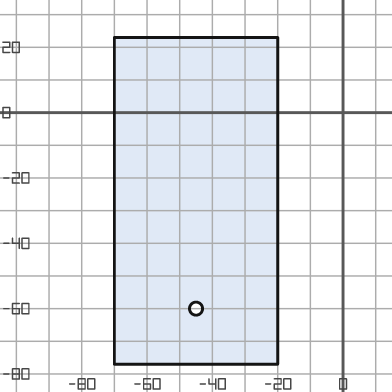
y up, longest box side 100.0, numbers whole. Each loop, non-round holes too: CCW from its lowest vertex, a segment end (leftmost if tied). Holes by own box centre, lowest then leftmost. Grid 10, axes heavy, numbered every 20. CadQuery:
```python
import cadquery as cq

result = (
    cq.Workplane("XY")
    .moveTo(-70.0, -77.0)
    .lineTo(-20.0, -77.0)
    .lineTo(-20.0, 23.0)
    .lineTo(-70.0, 23.0)
    .close()
    .moveTo(-45.0, -60.0)
    .circle(2.0)
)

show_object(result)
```